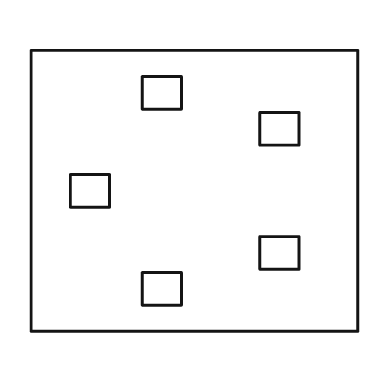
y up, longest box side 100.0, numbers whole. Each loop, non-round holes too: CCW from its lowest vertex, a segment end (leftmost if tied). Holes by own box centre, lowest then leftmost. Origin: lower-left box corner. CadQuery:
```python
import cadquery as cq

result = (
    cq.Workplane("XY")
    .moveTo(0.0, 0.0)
    .lineTo(100.0, 0.0)
    .lineTo(100.0, 86.0)
    .lineTo(0.0, 86.0)
    .close()
    .moveTo(34.0, 8.0)
    .lineTo(46.0, 8.0)
    .lineTo(46.0, 18.0)
    .lineTo(34.0, 18.0)
    .close()
    .moveTo(70.0, 19.0)
    .lineTo(82.0, 19.0)
    .lineTo(82.0, 29.0)
    .lineTo(70.0, 29.0)
    .close()
    .moveTo(12.0, 38.0)
    .lineTo(24.0, 38.0)
    .lineTo(24.0, 48.0)
    .lineTo(12.0, 48.0)
    .close()
    .moveTo(70.0, 57.0)
    .lineTo(82.0, 57.0)
    .lineTo(82.0, 67.0)
    .lineTo(70.0, 67.0)
    .close()
    .moveTo(34.0, 68.0)
    .lineTo(46.0, 68.0)
    .lineTo(46.0, 78.0)
    .lineTo(34.0, 78.0)
    .close()
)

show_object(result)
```